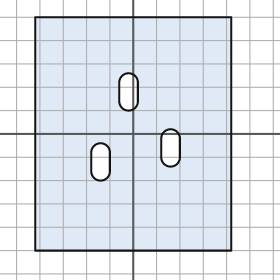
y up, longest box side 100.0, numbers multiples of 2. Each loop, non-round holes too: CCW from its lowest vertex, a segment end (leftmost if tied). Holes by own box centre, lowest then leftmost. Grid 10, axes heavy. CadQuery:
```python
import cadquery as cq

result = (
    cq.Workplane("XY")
    .moveTo(-42.0, -50.0)
    .lineTo(42.0, -50.0)
    .lineTo(42.0, 50.0)
    .lineTo(-42.0, 50.0)
    .close()
    .moveTo(-18.0, -16.0)
    .threePointArc((-14.0, -20.0), (-10.0, -16.0))
    .lineTo(-10.0, -8.0)
    .threePointArc((-14.0, -4.0), (-18.0, -8.0))
    .close()
    .moveTo(12.0, -10.0)
    .threePointArc((16.0, -14.0), (20.0, -10.0))
    .lineTo(20.0, -2.0)
    .threePointArc((16.0, 2.0), (12.0, -2.0))
    .close()
    .moveTo(-6.0, 14.0)
    .threePointArc((-2.0, 10.0), (2.0, 14.0))
    .lineTo(2.0, 22.0)
    .threePointArc((-2.0, 26.0), (-6.0, 22.0))
    .close()
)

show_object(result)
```